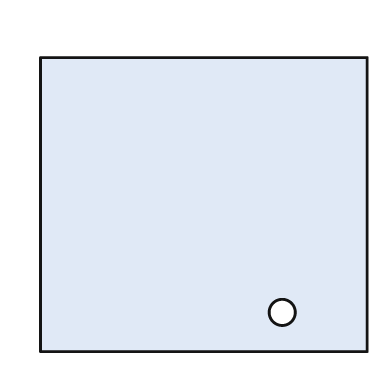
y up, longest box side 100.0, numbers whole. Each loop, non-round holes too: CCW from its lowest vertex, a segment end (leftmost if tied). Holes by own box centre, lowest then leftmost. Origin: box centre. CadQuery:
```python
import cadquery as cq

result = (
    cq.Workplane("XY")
    .moveTo(-50.0, -45.0)
    .lineTo(50.0, -45.0)
    .lineTo(50.0, 45.0)
    .lineTo(-50.0, 45.0)
    .close()
    .moveTo(24.0, -33.0)
    .circle(4.0)
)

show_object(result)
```